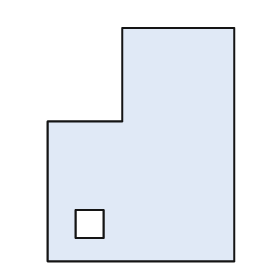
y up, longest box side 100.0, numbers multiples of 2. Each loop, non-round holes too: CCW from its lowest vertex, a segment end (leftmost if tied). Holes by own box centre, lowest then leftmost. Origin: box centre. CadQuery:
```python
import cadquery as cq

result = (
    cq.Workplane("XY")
    .moveTo(-40.0, -50.0)
    .lineTo(40.0, -50.0)
    .lineTo(40.0, 50.0)
    .lineTo(-8.0, 50.0)
    .lineTo(-8.0, 10.0)
    .lineTo(-40.0, 10.0)
    .close()
    .moveTo(-28.0, -40.0)
    .lineTo(-16.0, -40.0)
    .lineTo(-16.0, -28.0)
    .lineTo(-28.0, -28.0)
    .close()
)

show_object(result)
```